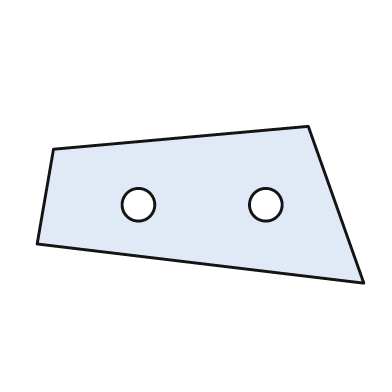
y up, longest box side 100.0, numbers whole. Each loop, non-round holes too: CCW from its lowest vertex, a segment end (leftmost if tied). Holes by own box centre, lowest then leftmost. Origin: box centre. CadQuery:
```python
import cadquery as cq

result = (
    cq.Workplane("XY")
    .moveTo(50.0, -24.0)
    .lineTo(33.0, 24.0)
    .lineTo(-45.0, 17.0)
    .lineTo(-50.0, -12.0)
    .close()
    .moveTo(-19.0, 0.0)
    .circle(5.0)
    .moveTo(20.0, 0.0)
    .circle(5.0)
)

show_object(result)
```